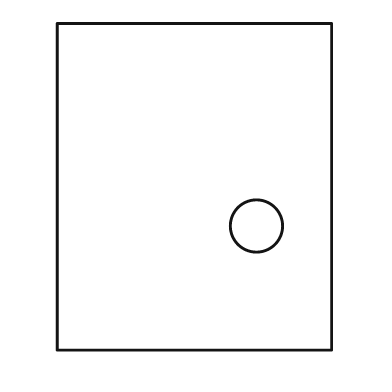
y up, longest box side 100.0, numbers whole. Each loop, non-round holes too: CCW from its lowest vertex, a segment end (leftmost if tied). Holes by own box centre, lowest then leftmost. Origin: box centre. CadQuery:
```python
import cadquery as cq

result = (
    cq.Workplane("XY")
    .moveTo(-42.0, -50.0)
    .lineTo(42.0, -50.0)
    .lineTo(42.0, 50.0)
    .lineTo(-42.0, 50.0)
    .close()
    .moveTo(19.0, -12.0)
    .circle(8.0)
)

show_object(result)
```